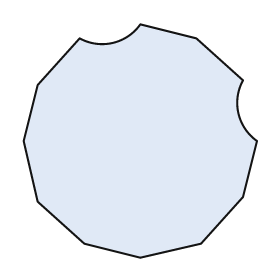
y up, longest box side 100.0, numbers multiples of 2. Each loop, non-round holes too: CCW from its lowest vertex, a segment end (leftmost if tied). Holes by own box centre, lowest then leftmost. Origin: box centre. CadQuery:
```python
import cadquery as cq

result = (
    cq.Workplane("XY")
    .moveTo(0.0, -50.0)
    .lineTo(26.0, -44.0)
    .lineTo(44.0, -24.0)
    .lineTo(50.0, 0.0)
    .threePointArc((42.0, 12.0), (44.0, 26.0))
    .lineTo(24.0, 44.0)
    .lineTo(0.0, 50.0)
    .threePointArc((-12.0, 42.0), (-26.0, 44.0))
    .lineTo(-44.0, 24.0)
    .lineTo(-50.0, 0.0)
    .lineTo(-44.0, -26.0)
    .lineTo(-24.0, -44.0)
    .close()
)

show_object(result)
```